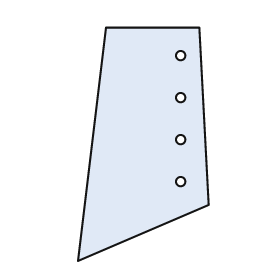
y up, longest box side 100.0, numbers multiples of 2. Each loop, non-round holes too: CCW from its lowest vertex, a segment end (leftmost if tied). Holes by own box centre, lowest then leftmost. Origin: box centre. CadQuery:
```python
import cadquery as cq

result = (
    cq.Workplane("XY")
    .moveTo(-28.0, -50.0)
    .lineTo(28.0, -26.0)
    .lineTo(24.0, 50.0)
    .lineTo(-16.0, 50.0)
    .close()
    .moveTo(16.0, -16.0)
    .circle(2.0)
    .moveTo(16.0, 2.0)
    .circle(2.0)
    .moveTo(16.0, 20.0)
    .circle(2.0)
    .moveTo(16.0, 38.0)
    .circle(2.0)
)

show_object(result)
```